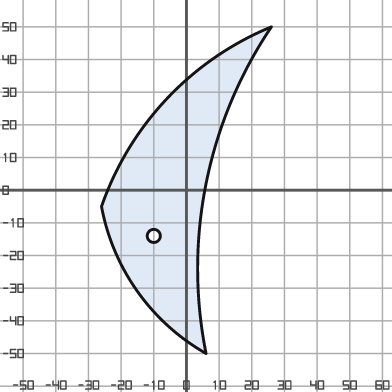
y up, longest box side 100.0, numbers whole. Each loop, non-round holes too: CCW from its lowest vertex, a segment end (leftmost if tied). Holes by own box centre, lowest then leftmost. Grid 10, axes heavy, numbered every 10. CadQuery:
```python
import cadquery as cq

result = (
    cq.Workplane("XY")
    .moveTo(6.0, -50.0)
    .threePointArc((6.0, 2.0), (26.0, 50.0))
    .threePointArc((-6.0, 28.0), (-26.0, -5.0))
    .threePointArc((-15.0, -31.0), (6.0, -50.0))
    .close()
    .moveTo(-10.0, -14.0)
    .circle(2.0)
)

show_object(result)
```